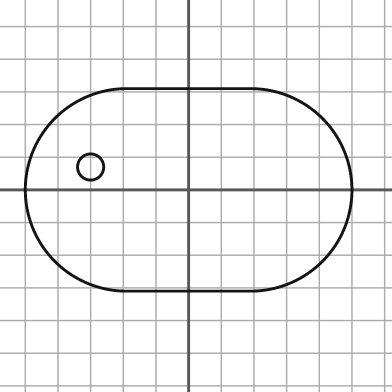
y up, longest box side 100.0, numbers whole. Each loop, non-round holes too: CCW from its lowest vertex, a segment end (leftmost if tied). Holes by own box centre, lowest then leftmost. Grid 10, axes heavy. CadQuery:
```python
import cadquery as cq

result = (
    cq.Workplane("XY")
    .moveTo(-19.0, -31.0)
    .lineTo(19.0, -31.0)
    .threePointArc((50.0, 0.0), (19.0, 31.0))
    .lineTo(-19.0, 31.0)
    .threePointArc((-50.0, 0.0), (-19.0, -31.0))
    .close()
    .moveTo(-30.0, 7.0)
    .circle(4.0)
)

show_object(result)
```